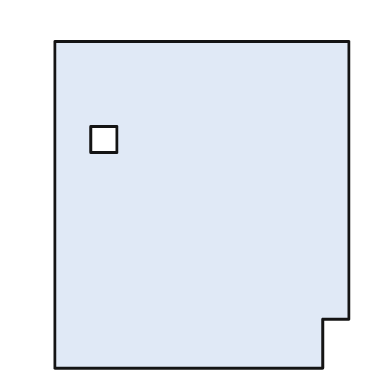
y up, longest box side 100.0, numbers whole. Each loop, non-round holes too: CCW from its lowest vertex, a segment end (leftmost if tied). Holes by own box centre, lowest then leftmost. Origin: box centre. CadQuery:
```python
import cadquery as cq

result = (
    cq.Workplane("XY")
    .moveTo(-45.0, -50.0)
    .lineTo(37.0, -50.0)
    .lineTo(37.0, -35.0)
    .lineTo(45.0, -35.0)
    .lineTo(45.0, 50.0)
    .lineTo(-45.0, 50.0)
    .close()
    .moveTo(-34.0, 16.0)
    .lineTo(-26.0, 16.0)
    .lineTo(-26.0, 24.0)
    .lineTo(-34.0, 24.0)
    .close()
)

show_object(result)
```